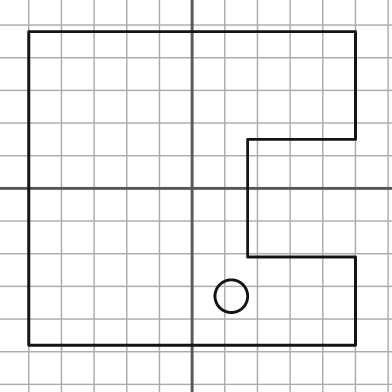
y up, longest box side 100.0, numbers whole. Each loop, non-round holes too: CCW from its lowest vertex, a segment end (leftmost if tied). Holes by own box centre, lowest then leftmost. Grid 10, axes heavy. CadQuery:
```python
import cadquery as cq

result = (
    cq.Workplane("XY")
    .moveTo(-50.0, -48.0)
    .lineTo(50.0, -48.0)
    .lineTo(50.0, -21.0)
    .lineTo(17.0, -21.0)
    .lineTo(17.0, 15.0)
    .lineTo(50.0, 15.0)
    .lineTo(50.0, 48.0)
    .lineTo(-50.0, 48.0)
    .close()
    .moveTo(12.0, -33.0)
    .circle(5.0)
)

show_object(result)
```